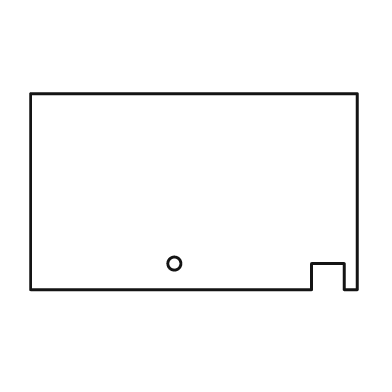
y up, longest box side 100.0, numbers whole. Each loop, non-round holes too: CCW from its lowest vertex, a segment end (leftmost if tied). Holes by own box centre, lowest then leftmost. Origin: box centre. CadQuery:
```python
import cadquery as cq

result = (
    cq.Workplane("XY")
    .moveTo(-50.0, -30.0)
    .lineTo(36.0, -30.0)
    .lineTo(36.0, -22.0)
    .lineTo(46.0, -22.0)
    .lineTo(46.0, -30.0)
    .lineTo(50.0, -30.0)
    .lineTo(50.0, 30.0)
    .lineTo(-50.0, 30.0)
    .close()
    .moveTo(-6.0, -22.0)
    .circle(2.0)
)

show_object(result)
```